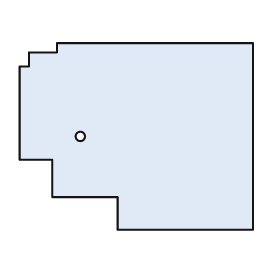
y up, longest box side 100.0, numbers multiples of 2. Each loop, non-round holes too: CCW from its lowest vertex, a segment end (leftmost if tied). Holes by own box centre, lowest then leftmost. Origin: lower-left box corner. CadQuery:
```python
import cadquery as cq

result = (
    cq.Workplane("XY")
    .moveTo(42.0, 0.0)
    .lineTo(100.0, 0.0)
    .lineTo(100.0, 80.0)
    .lineTo(16.0, 80.0)
    .lineTo(16.0, 76.0)
    .lineTo(4.0, 76.0)
    .lineTo(4.0, 70.0)
    .lineTo(0.0, 70.0)
    .lineTo(0.0, 30.0)
    .lineTo(14.0, 30.0)
    .lineTo(14.0, 14.0)
    .lineTo(42.0, 14.0)
    .close()
    .moveTo(26.0, 40.0)
    .circle(2.0)
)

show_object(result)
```